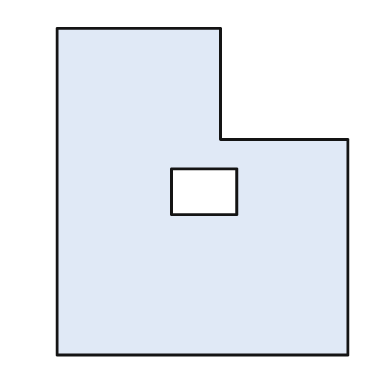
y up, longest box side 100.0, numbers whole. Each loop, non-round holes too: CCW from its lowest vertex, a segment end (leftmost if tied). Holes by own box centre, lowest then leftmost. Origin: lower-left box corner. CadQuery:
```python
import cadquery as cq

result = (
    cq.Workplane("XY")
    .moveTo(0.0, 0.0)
    .lineTo(89.0, 0.0)
    .lineTo(89.0, 66.0)
    .lineTo(50.0, 66.0)
    .lineTo(50.0, 100.0)
    .lineTo(0.0, 100.0)
    .close()
    .moveTo(35.0, 43.0)
    .lineTo(55.0, 43.0)
    .lineTo(55.0, 57.0)
    .lineTo(35.0, 57.0)
    .close()
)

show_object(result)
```